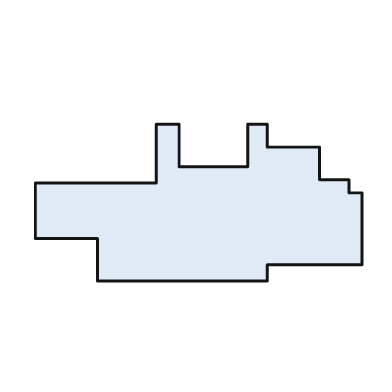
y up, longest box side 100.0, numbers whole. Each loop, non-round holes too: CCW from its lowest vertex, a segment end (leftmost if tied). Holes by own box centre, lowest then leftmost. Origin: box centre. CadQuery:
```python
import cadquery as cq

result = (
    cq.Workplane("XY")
    .moveTo(-31.0, -24.0)
    .lineTo(21.0, -24.0)
    .lineTo(21.0, -19.0)
    .lineTo(50.0, -19.0)
    .lineTo(50.0, 3.0)
    .lineTo(46.0, 3.0)
    .lineTo(46.0, 7.0)
    .lineTo(37.0, 7.0)
    .lineTo(37.0, 17.0)
    .lineTo(21.0, 17.0)
    .lineTo(21.0, 24.0)
    .lineTo(15.0, 24.0)
    .lineTo(15.0, 11.0)
    .lineTo(-6.0, 11.0)
    .lineTo(-6.0, 24.0)
    .lineTo(-13.0, 24.0)
    .lineTo(-13.0, 6.0)
    .lineTo(-50.0, 6.0)
    .lineTo(-50.0, -11.0)
    .lineTo(-31.0, -11.0)
    .close()
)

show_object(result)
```